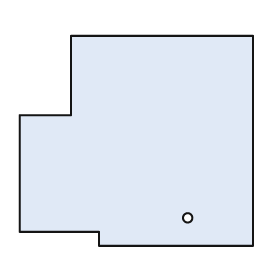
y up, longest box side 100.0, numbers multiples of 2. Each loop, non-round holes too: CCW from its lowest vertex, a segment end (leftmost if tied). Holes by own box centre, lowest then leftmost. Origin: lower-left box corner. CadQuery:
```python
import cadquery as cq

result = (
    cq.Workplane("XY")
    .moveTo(34.0, 0.0)
    .lineTo(100.0, 0.0)
    .lineTo(100.0, 90.0)
    .lineTo(22.0, 90.0)
    .lineTo(22.0, 56.0)
    .lineTo(0.0, 56.0)
    .lineTo(0.0, 6.0)
    .lineTo(34.0, 6.0)
    .close()
    .moveTo(72.0, 12.0)
    .circle(2.0)
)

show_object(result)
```